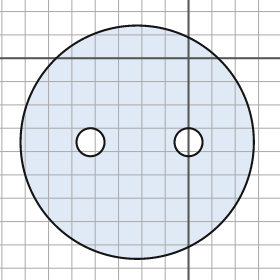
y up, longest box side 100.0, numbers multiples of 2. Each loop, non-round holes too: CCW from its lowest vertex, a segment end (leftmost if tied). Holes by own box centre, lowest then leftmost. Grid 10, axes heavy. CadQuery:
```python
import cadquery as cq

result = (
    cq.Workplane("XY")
    .moveTo(-22.0, -36.0)
    .circle(50.0)
    .moveTo(-42.0, -36.0)
    .circle(6.0)
    .moveTo(0.0, -36.0)
    .circle(6.0)
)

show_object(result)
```